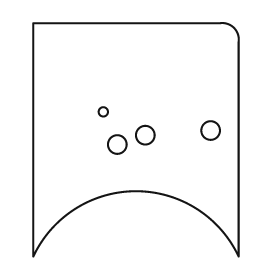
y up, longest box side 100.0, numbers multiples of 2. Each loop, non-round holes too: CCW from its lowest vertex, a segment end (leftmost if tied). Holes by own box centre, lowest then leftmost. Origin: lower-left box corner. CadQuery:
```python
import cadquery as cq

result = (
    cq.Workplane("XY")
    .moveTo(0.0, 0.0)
    .threePointArc((44.0, 28.0), (88.0, 0.0))
    .lineTo(88.0, 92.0)
    .threePointArc((86.0, 98.0), (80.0, 100.0))
    .lineTo(0.0, 100.0)
    .close()
    .moveTo(36.0, 48.0)
    .circle(4.0)
    .moveTo(48.0, 52.0)
    .circle(4.0)
    .moveTo(76.0, 54.0)
    .circle(4.0)
    .moveTo(30.0, 62.0)
    .circle(2.0)
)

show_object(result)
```